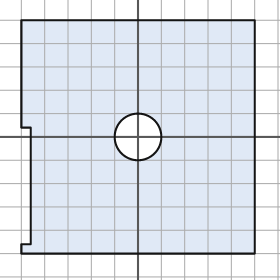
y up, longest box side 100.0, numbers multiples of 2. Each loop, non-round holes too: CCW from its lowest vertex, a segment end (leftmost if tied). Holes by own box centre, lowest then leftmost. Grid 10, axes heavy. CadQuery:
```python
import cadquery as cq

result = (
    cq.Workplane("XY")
    .moveTo(-50.0, -50.0)
    .lineTo(50.0, -50.0)
    .lineTo(50.0, 50.0)
    .lineTo(-50.0, 50.0)
    .lineTo(-50.0, 4.0)
    .lineTo(-46.0, 4.0)
    .lineTo(-46.0, -46.0)
    .lineTo(-50.0, -46.0)
    .close()
    .moveTo(0.0, 0.0)
    .circle(10.0)
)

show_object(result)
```